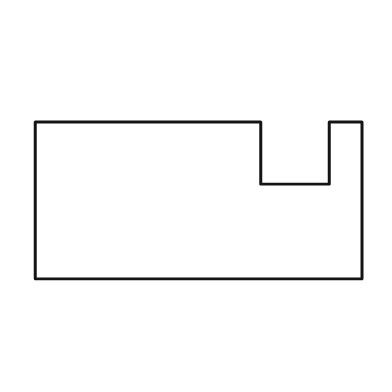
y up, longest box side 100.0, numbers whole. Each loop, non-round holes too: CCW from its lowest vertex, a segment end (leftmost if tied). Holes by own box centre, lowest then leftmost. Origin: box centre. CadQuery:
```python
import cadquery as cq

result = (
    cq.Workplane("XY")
    .moveTo(-50.0, -24.0)
    .lineTo(50.0, -24.0)
    .lineTo(50.0, 24.0)
    .lineTo(40.0, 24.0)
    .lineTo(40.0, 5.0)
    .lineTo(19.0, 5.0)
    .lineTo(19.0, 24.0)
    .lineTo(-50.0, 24.0)
    .close()
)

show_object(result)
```